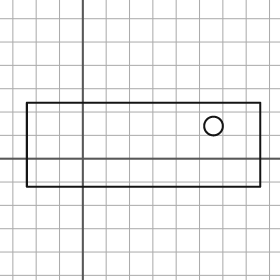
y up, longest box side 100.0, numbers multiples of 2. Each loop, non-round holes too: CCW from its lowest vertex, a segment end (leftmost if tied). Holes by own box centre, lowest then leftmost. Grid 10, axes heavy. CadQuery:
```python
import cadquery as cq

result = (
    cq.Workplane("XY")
    .moveTo(-24.0, -12.0)
    .lineTo(76.0, -12.0)
    .lineTo(76.0, 24.0)
    .lineTo(-24.0, 24.0)
    .close()
    .moveTo(56.0, 14.0)
    .circle(4.0)
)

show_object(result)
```